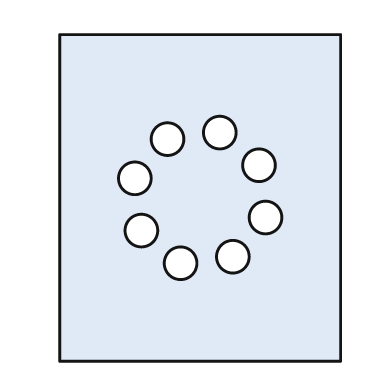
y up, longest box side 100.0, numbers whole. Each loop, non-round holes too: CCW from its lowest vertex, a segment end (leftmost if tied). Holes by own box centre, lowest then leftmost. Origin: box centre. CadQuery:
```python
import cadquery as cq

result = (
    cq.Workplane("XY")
    .moveTo(-43.0, -50.0)
    .lineTo(43.0, -50.0)
    .lineTo(43.0, 50.0)
    .lineTo(-43.0, 50.0)
    .close()
    .moveTo(-6.0, -20.0)
    .circle(5.0)
    .moveTo(10.0, -18.0)
    .circle(5.0)
    .moveTo(-18.0, -10.0)
    .circle(5.0)
    .moveTo(20.0, -6.0)
    .circle(5.0)
    .moveTo(-20.0, 6.0)
    .circle(5.0)
    .moveTo(18.0, 10.0)
    .circle(5.0)
    .moveTo(-10.0, 18.0)
    .circle(5.0)
    .moveTo(6.0, 20.0)
    .circle(5.0)
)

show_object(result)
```